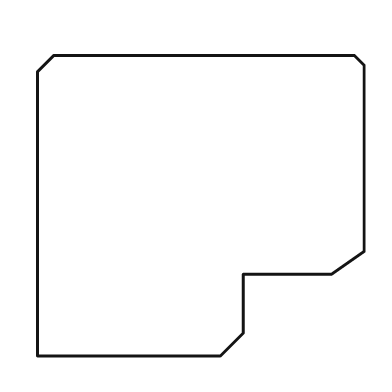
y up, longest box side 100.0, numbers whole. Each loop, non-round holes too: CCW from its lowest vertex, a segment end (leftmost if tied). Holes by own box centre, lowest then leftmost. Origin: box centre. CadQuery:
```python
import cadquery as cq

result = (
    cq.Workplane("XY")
    .moveTo(-50.0, -46.0)
    .lineTo(6.0, -46.0)
    .lineTo(13.0, -39.0)
    .lineTo(13.0, -21.0)
    .lineTo(40.0, -21.0)
    .lineTo(50.0, -14.0)
    .lineTo(50.0, 43.0)
    .lineTo(47.0, 46.0)
    .lineTo(-45.0, 46.0)
    .lineTo(-50.0, 41.0)
    .close()
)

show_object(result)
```